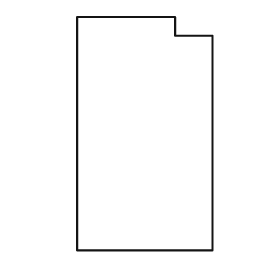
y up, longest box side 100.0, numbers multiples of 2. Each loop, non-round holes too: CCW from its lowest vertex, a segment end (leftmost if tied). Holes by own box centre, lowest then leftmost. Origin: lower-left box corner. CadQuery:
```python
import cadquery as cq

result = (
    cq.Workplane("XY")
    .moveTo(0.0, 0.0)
    .lineTo(58.0, 0.0)
    .lineTo(58.0, 92.0)
    .lineTo(42.0, 92.0)
    .lineTo(42.0, 100.0)
    .lineTo(0.0, 100.0)
    .close()
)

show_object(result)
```